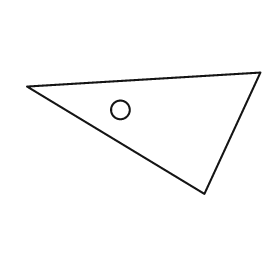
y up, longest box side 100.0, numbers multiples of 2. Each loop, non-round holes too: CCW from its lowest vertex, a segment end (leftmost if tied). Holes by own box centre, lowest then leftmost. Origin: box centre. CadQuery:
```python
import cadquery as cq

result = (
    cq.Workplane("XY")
    .moveTo(26.0, -26.0)
    .lineTo(50.0, 26.0)
    .lineTo(-50.0, 20.0)
    .close()
    .moveTo(-10.0, 10.0)
    .circle(4.0)
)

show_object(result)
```